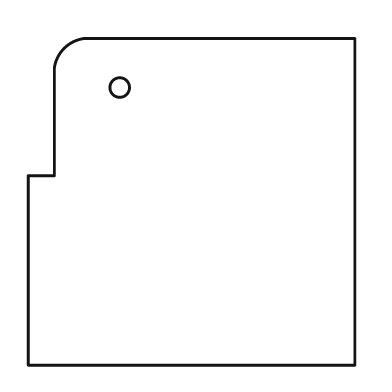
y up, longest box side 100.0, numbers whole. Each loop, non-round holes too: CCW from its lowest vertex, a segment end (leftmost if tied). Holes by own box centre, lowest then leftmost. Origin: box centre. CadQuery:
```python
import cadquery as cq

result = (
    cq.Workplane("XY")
    .moveTo(-50.0, -50.0)
    .lineTo(50.0, -50.0)
    .lineTo(50.0, 50.0)
    .lineTo(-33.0, 50.0)
    .threePointArc((-39.0, 47.0), (-42.0, 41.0))
    .lineTo(-42.0, 8.0)
    .lineTo(-50.0, 8.0)
    .close()
    .moveTo(-22.0, 35.0)
    .circle(3.0)
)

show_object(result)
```